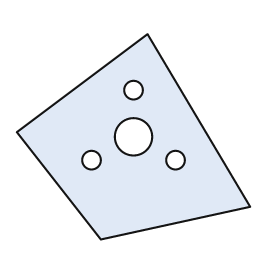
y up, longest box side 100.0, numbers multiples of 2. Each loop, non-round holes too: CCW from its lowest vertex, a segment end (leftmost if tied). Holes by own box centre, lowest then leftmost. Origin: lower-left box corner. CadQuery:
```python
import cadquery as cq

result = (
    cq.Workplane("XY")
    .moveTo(36.0, 0.0)
    .lineTo(100.0, 14.0)
    .lineTo(56.0, 88.0)
    .lineTo(0.0, 46.0)
    .close()
    .moveTo(32.0, 34.0)
    .circle(4.0)
    .moveTo(68.0, 34.0)
    .circle(4.0)
    .moveTo(50.0, 44.0)
    .circle(8.0)
    .moveTo(50.0, 64.0)
    .circle(4.0)
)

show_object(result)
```